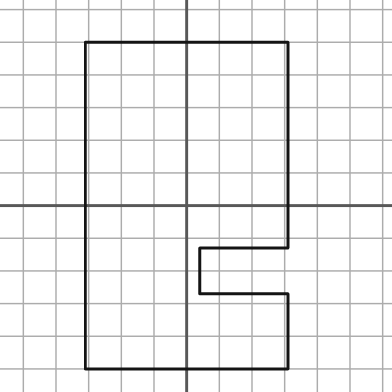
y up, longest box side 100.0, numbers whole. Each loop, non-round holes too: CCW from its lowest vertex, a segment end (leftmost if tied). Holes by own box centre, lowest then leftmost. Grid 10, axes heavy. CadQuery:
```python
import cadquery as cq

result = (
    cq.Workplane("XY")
    .moveTo(-31.0, -50.0)
    .lineTo(31.0, -50.0)
    .lineTo(31.0, -27.0)
    .lineTo(4.0, -27.0)
    .lineTo(4.0, -13.0)
    .lineTo(31.0, -13.0)
    .lineTo(31.0, 50.0)
    .lineTo(-31.0, 50.0)
    .close()
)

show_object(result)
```